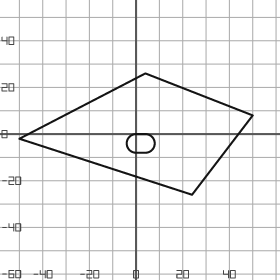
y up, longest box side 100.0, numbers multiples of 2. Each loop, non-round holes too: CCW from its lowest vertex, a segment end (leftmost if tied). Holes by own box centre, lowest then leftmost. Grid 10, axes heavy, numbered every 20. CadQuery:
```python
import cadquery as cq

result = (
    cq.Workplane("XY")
    .moveTo(24.0, -26.0)
    .lineTo(50.0, 8.0)
    .lineTo(4.0, 26.0)
    .lineTo(-50.0, -2.0)
    .close()
    .moveTo(0.0, -8.0)
    .lineTo(4.0, -8.0)
    .threePointArc((8.0, -4.0), (4.0, 0.0))
    .lineTo(0.0, 0.0)
    .threePointArc((-4.0, -4.0), (0.0, -8.0))
    .close()
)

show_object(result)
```